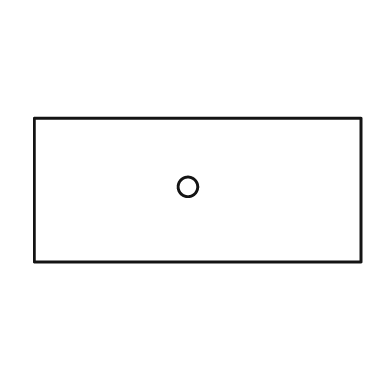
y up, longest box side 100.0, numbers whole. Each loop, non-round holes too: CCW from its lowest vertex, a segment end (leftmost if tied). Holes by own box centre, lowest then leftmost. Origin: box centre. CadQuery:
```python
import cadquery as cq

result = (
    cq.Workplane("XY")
    .moveTo(-50.0, -22.0)
    .lineTo(50.0, -22.0)
    .lineTo(50.0, 22.0)
    .lineTo(-50.0, 22.0)
    .close()
    .moveTo(-3.0, 1.0)
    .circle(3.0)
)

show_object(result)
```